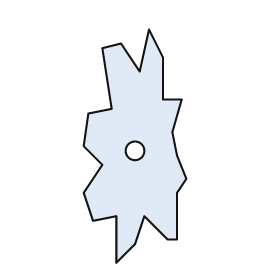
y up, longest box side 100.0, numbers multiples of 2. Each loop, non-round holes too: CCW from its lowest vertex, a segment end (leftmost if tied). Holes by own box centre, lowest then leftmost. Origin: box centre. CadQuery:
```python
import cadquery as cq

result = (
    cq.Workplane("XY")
    .moveTo(-8.0, -50.0)
    .lineTo(0.0, -42.0)
    .lineTo(4.0, -30.0)
    .lineTo(14.0, -40.0)
    .lineTo(18.0, -40.0)
    .lineTo(18.0, -20.0)
    .lineTo(22.0, -14.0)
    .lineTo(18.0, -4.0)
    .lineTo(16.0, 6.0)
    .lineTo(20.0, 20.0)
    .lineTo(12.0, 20.0)
    .lineTo(12.0, 38.0)
    .lineTo(6.0, 50.0)
    .lineTo(2.0, 32.0)
    .lineTo(-6.0, 44.0)
    .lineTo(-14.0, 42.0)
    .lineTo(-10.0, 16.0)
    .lineTo(-20.0, 14.0)
    .lineTo(-22.0, 0.0)
    .lineTo(-14.0, -8.0)
    .lineTo(-22.0, -20.0)
    .lineTo(-18.0, -32.0)
    .lineTo(-8.0, -30.0)
    .close()
    .moveTo(0.0, -2.0)
    .circle(4.0)
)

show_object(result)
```